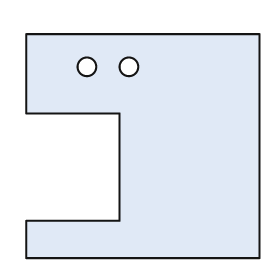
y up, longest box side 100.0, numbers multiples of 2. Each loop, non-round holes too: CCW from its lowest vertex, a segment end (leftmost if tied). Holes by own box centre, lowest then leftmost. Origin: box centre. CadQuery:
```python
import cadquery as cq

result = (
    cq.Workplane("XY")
    .moveTo(-50.0, -48.0)
    .lineTo(50.0, -48.0)
    .lineTo(50.0, 48.0)
    .lineTo(-50.0, 48.0)
    .lineTo(-50.0, 14.0)
    .lineTo(-10.0, 14.0)
    .lineTo(-10.0, -32.0)
    .lineTo(-50.0, -32.0)
    .close()
    .moveTo(-24.0, 34.0)
    .circle(4.0)
    .moveTo(-6.0, 34.0)
    .circle(4.0)
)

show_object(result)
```